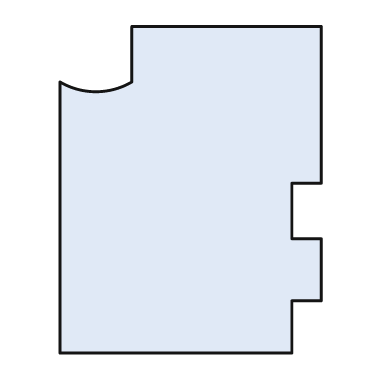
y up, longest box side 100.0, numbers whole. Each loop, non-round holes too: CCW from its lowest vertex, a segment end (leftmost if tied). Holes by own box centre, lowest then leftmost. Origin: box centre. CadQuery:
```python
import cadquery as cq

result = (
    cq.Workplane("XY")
    .moveTo(-40.0, -50.0)
    .lineTo(31.0, -50.0)
    .lineTo(31.0, -34.0)
    .lineTo(40.0, -34.0)
    .lineTo(40.0, -15.0)
    .lineTo(31.0, -15.0)
    .lineTo(31.0, 2.0)
    .lineTo(40.0, 2.0)
    .lineTo(40.0, 50.0)
    .lineTo(-18.0, 50.0)
    .lineTo(-18.0, 33.0)
    .threePointArc((-29.0, 30.0), (-40.0, 33.0))
    .close()
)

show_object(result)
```